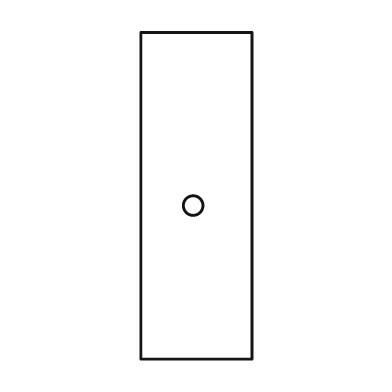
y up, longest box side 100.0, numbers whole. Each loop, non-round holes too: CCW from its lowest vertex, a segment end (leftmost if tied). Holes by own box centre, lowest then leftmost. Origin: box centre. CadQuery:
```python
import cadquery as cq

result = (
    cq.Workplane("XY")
    .moveTo(-17.0, -50.0)
    .lineTo(17.0, -50.0)
    .lineTo(17.0, 50.0)
    .lineTo(-17.0, 50.0)
    .close()
    .moveTo(-1.0, -3.0)
    .circle(3.0)
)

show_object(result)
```